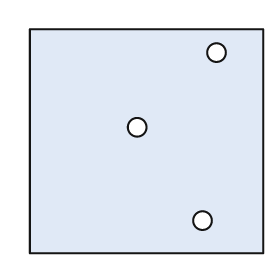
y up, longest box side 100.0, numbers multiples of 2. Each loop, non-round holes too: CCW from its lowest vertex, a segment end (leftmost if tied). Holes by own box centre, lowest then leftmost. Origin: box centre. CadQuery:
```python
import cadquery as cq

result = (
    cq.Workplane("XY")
    .moveTo(-50.0, -48.0)
    .lineTo(50.0, -48.0)
    .lineTo(50.0, 48.0)
    .lineTo(-50.0, 48.0)
    .close()
    .moveTo(24.0, -34.0)
    .circle(4.0)
    .moveTo(-4.0, 6.0)
    .circle(4.0)
    .moveTo(30.0, 38.0)
    .circle(4.0)
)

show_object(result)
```